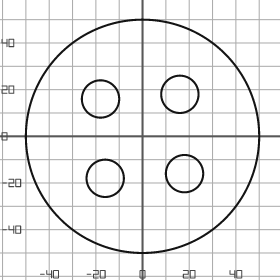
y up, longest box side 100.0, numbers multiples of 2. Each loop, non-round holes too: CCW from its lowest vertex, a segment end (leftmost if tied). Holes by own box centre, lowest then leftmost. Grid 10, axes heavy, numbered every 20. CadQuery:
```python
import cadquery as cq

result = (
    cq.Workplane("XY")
    .moveTo(0.0, 0.0)
    .circle(50.0)
    .moveTo(-16.0, -18.0)
    .circle(8.0)
    .moveTo(18.0, -16.0)
    .circle(8.0)
    .moveTo(-18.0, 16.0)
    .circle(8.0)
    .moveTo(16.0, 18.0)
    .circle(8.0)
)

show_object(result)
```